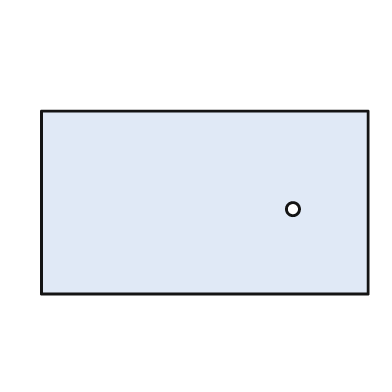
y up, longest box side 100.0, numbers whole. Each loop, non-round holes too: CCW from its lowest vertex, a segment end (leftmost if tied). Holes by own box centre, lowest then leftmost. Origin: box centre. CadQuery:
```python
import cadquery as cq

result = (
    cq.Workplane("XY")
    .moveTo(-50.0, -28.0)
    .lineTo(50.0, -28.0)
    .lineTo(50.0, 28.0)
    .lineTo(-50.0, 28.0)
    .close()
    .moveTo(27.0, -2.0)
    .circle(2.0)
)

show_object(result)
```